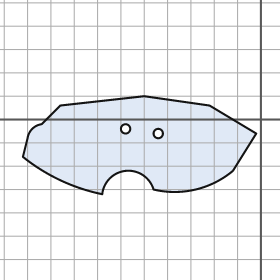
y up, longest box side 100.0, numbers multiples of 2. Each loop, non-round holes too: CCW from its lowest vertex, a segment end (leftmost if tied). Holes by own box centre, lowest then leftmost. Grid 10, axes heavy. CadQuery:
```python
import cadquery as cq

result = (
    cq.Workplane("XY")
    .moveTo(-68.0, -32.0)
    .threePointArc((-58.0, -22.0), (-46.0, -30.0))
    .threePointArc((-28.0, -30.0), (-12.0, -22.0))
    .lineTo(-2.0, -6.0)
    .lineTo(-22.0, 6.0)
    .lineTo(-50.0, 10.0)
    .lineTo(-86.0, 6.0)
    .lineTo(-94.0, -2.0)
    .threePointArc((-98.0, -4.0), (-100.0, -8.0))
    .lineTo(-102.0, -16.0)
    .threePointArc((-86.0, -26.0), (-68.0, -32.0))
    .close()
    .moveTo(-44.0, -6.0)
    .circle(2.0)
    .moveTo(-58.0, -4.0)
    .circle(2.0)
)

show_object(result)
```